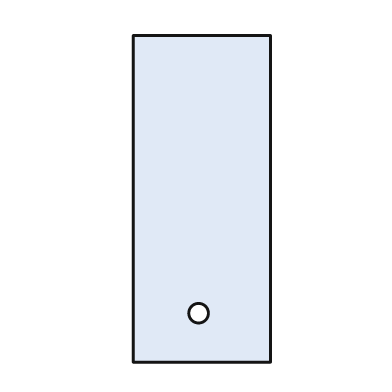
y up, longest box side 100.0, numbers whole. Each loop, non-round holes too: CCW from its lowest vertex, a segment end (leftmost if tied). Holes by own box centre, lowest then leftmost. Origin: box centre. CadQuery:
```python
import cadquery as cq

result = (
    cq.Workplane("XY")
    .moveTo(-21.0, -50.0)
    .lineTo(21.0, -50.0)
    .lineTo(21.0, 50.0)
    .lineTo(-21.0, 50.0)
    .close()
    .moveTo(-1.0, -35.0)
    .circle(3.0)
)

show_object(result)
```